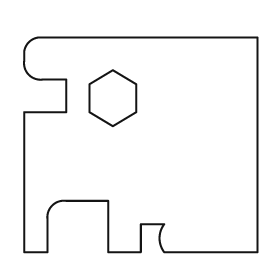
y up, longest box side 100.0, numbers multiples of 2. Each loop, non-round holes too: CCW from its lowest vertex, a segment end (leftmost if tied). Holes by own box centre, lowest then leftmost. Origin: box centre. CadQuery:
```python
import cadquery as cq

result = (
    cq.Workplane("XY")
    .moveTo(-50.0, -46.0)
    .lineTo(-40.0, -46.0)
    .lineTo(-40.0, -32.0)
    .threePointArc((-38.0, -26.0), (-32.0, -24.0))
    .lineTo(-14.0, -24.0)
    .lineTo(-14.0, -46.0)
    .lineTo(0.0, -46.0)
    .lineTo(0.0, -34.0)
    .lineTo(10.0, -34.0)
    .threePointArc((8.0, -40.0), (10.0, -46.0))
    .lineTo(50.0, -46.0)
    .lineTo(50.0, 46.0)
    .lineTo(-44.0, 46.0)
    .threePointArc((-48.0, 44.0), (-50.0, 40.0))
    .lineTo(-50.0, 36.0)
    .threePointArc((-48.0, 30.0), (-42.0, 28.0))
    .lineTo(-32.0, 28.0)
    .lineTo(-32.0, 14.0)
    .lineTo(-50.0, 14.0)
    .close()
    .moveTo(-12.0, 8.0)
    .lineTo(-2.0, 14.0)
    .lineTo(-2.0, 26.0)
    .lineTo(-12.0, 32.0)
    .lineTo(-22.0, 26.0)
    .lineTo(-22.0, 14.0)
    .close()
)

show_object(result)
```